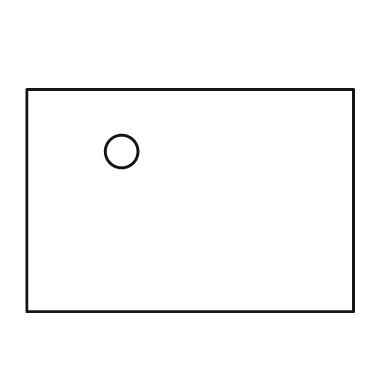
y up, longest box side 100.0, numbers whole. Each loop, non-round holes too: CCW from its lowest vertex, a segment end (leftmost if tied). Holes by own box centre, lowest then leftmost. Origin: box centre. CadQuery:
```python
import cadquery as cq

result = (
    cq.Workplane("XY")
    .moveTo(-50.0, -34.0)
    .lineTo(50.0, -34.0)
    .lineTo(50.0, 34.0)
    .lineTo(-50.0, 34.0)
    .close()
    .moveTo(-21.0, 15.0)
    .circle(5.0)
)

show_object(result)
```